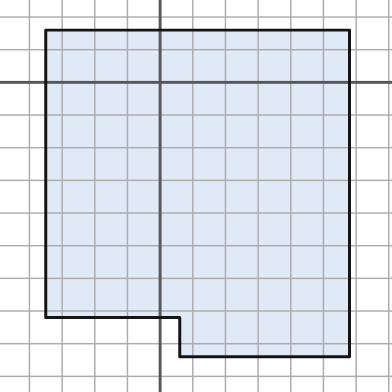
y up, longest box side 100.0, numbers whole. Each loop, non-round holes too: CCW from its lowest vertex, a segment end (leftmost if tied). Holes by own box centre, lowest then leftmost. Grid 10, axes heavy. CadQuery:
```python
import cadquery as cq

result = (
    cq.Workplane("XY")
    .moveTo(6.0, -84.0)
    .lineTo(58.0, -84.0)
    .lineTo(58.0, 16.0)
    .lineTo(-35.0, 16.0)
    .lineTo(-35.0, -72.0)
    .lineTo(6.0, -72.0)
    .close()
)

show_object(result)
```